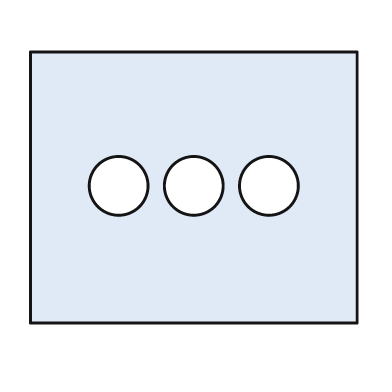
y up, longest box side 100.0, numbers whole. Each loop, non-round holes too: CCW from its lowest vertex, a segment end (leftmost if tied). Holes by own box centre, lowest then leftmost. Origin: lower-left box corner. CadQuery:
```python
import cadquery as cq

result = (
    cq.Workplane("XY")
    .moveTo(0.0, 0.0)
    .lineTo(100.0, 0.0)
    .lineTo(100.0, 83.0)
    .lineTo(0.0, 83.0)
    .close()
    .moveTo(27.0, 42.0)
    .circle(9.0)
    .moveTo(50.0, 42.0)
    .circle(9.0)
    .moveTo(73.0, 42.0)
    .circle(9.0)
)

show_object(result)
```